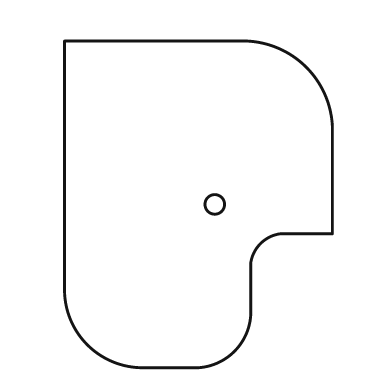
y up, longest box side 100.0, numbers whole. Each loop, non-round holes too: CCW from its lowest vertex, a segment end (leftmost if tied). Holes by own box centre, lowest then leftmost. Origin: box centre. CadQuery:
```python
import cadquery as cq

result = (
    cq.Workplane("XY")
    .moveTo(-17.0, -50.0)
    .lineTo(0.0, -50.0)
    .threePointArc((11.0, -45.0), (16.0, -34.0))
    .lineTo(16.0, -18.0)
    .threePointArc((19.0, -12.0), (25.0, -9.0))
    .lineTo(41.0, -9.0)
    .lineTo(41.0, 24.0)
    .threePointArc((33.0, 42.0), (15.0, 50.0))
    .lineTo(-41.0, 50.0)
    .lineTo(-41.0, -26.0)
    .threePointArc((-34.0, -43.0), (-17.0, -50.0))
    .close()
    .moveTo(5.0, 0.0)
    .circle(3.0)
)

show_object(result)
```